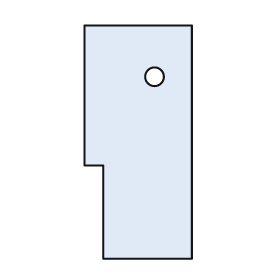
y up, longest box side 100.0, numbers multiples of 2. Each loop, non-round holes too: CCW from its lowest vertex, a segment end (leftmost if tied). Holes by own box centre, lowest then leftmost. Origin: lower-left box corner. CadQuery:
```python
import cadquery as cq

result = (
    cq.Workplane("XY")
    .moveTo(8.0, 0.0)
    .lineTo(46.0, 0.0)
    .lineTo(46.0, 100.0)
    .lineTo(0.0, 100.0)
    .lineTo(0.0, 40.0)
    .lineTo(8.0, 40.0)
    .close()
    .moveTo(30.0, 78.0)
    .circle(4.0)
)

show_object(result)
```